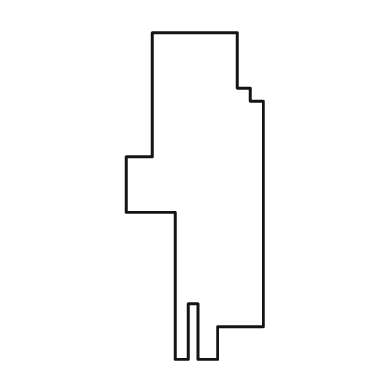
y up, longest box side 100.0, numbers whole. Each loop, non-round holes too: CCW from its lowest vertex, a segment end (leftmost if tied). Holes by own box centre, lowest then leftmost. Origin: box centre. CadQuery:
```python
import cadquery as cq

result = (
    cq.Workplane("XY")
    .moveTo(-6.0, -50.0)
    .lineTo(-2.0, -50.0)
    .lineTo(-2.0, -33.0)
    .lineTo(1.0, -33.0)
    .lineTo(1.0, -50.0)
    .lineTo(7.0, -50.0)
    .lineTo(7.0, -40.0)
    .lineTo(21.0, -40.0)
    .lineTo(21.0, 29.0)
    .lineTo(17.0, 29.0)
    .lineTo(17.0, 33.0)
    .lineTo(13.0, 33.0)
    .lineTo(13.0, 50.0)
    .lineTo(-13.0, 50.0)
    .lineTo(-13.0, 12.0)
    .lineTo(-21.0, 12.0)
    .lineTo(-21.0, -5.0)
    .lineTo(-6.0, -5.0)
    .close()
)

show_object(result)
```